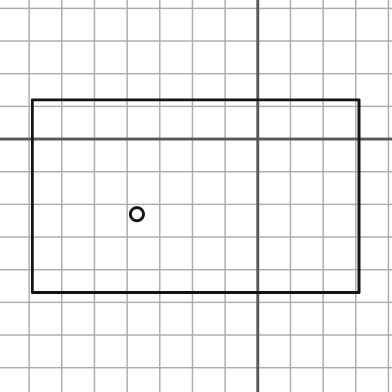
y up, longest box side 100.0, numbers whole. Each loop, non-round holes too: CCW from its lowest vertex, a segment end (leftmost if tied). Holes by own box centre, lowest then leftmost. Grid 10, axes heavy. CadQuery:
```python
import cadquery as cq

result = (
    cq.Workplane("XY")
    .moveTo(-69.0, -47.0)
    .lineTo(31.0, -47.0)
    .lineTo(31.0, 12.0)
    .lineTo(-69.0, 12.0)
    .close()
    .moveTo(-37.0, -23.0)
    .circle(2.0)
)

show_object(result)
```